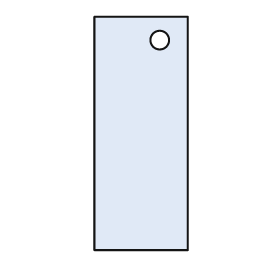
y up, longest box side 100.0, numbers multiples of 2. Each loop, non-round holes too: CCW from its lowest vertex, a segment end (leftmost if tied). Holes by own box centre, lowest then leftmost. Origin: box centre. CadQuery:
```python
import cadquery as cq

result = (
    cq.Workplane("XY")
    .moveTo(-20.0, -50.0)
    .lineTo(20.0, -50.0)
    .lineTo(20.0, 50.0)
    .lineTo(-20.0, 50.0)
    .close()
    .moveTo(8.0, 40.0)
    .circle(4.0)
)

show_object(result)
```